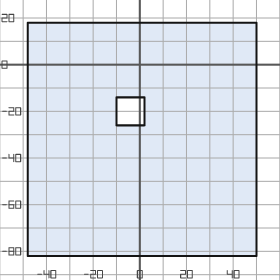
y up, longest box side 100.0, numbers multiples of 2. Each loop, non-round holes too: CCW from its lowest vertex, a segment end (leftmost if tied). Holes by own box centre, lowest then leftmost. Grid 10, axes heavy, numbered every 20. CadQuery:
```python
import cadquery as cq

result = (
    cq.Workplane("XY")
    .moveTo(-48.0, -82.0)
    .lineTo(50.0, -82.0)
    .lineTo(50.0, 18.0)
    .lineTo(-48.0, 18.0)
    .close()
    .moveTo(-10.0, -26.0)
    .lineTo(2.0, -26.0)
    .lineTo(2.0, -14.0)
    .lineTo(-10.0, -14.0)
    .close()
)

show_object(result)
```